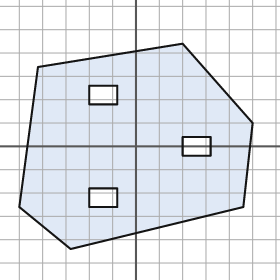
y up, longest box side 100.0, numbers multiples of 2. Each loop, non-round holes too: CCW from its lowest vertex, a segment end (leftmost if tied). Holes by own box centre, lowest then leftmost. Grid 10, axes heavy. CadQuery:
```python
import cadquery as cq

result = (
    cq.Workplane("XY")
    .moveTo(-28.0, -44.0)
    .lineTo(46.0, -26.0)
    .lineTo(50.0, 10.0)
    .lineTo(20.0, 44.0)
    .lineTo(-42.0, 34.0)
    .lineTo(-50.0, -26.0)
    .close()
    .moveTo(-20.0, -26.0)
    .lineTo(-8.0, -26.0)
    .lineTo(-8.0, -18.0)
    .lineTo(-20.0, -18.0)
    .close()
    .moveTo(20.0, -4.0)
    .lineTo(32.0, -4.0)
    .lineTo(32.0, 4.0)
    .lineTo(20.0, 4.0)
    .close()
    .moveTo(-20.0, 18.0)
    .lineTo(-8.0, 18.0)
    .lineTo(-8.0, 26.0)
    .lineTo(-20.0, 26.0)
    .close()
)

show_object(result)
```